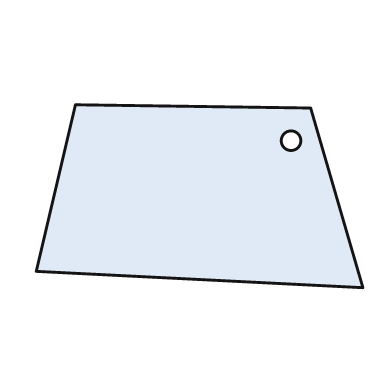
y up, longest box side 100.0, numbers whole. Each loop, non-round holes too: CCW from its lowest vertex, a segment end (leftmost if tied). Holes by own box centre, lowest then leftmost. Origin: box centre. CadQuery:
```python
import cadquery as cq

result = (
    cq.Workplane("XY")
    .moveTo(50.0, -28.0)
    .lineTo(34.0, 27.0)
    .lineTo(-38.0, 28.0)
    .lineTo(-50.0, -23.0)
    .close()
    .moveTo(28.0, 17.0)
    .circle(3.0)
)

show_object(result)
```